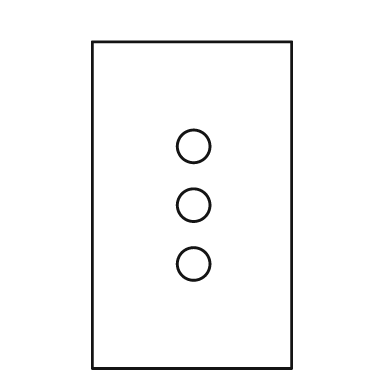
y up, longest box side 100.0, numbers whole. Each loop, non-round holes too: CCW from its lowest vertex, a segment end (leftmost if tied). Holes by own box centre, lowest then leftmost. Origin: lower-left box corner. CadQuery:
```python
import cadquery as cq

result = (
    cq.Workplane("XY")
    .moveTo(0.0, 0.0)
    .lineTo(61.0, 0.0)
    .lineTo(61.0, 100.0)
    .lineTo(0.0, 100.0)
    .close()
    .moveTo(31.0, 32.0)
    .circle(5.0)
    .moveTo(31.0, 50.0)
    .circle(5.0)
    .moveTo(31.0, 68.0)
    .circle(5.0)
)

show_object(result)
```